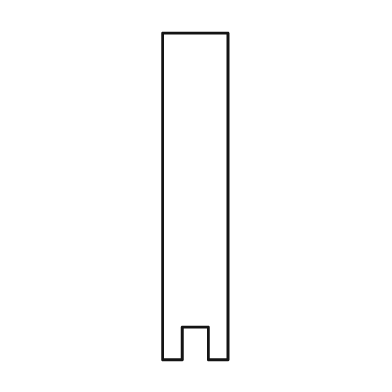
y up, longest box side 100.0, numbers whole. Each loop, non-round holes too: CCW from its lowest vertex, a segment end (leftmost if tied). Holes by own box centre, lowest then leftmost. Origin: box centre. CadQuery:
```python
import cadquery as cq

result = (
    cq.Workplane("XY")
    .moveTo(-10.0, -50.0)
    .lineTo(-4.0, -50.0)
    .lineTo(-4.0, -40.0)
    .lineTo(4.0, -40.0)
    .lineTo(4.0, -50.0)
    .lineTo(10.0, -50.0)
    .lineTo(10.0, 50.0)
    .lineTo(-10.0, 50.0)
    .close()
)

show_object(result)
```